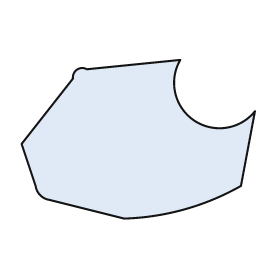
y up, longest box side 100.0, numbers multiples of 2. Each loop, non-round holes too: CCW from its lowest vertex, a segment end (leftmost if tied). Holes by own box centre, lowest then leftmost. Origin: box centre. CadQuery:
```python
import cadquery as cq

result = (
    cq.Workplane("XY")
    .moveTo(-6.0, -34.0)
    .threePointArc((20.0, -30.0), (44.0, -20.0))
    .lineTo(50.0, 12.0)
    .threePointArc((24.0, 8.0), (18.0, 34.0))
    .lineTo(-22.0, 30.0)
    .threePointArc((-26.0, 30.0), (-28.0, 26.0))
    .lineTo(-50.0, -2.0)
    .lineTo(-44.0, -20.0)
    .threePointArc((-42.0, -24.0), (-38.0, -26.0))
    .close()
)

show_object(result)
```